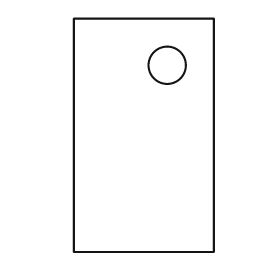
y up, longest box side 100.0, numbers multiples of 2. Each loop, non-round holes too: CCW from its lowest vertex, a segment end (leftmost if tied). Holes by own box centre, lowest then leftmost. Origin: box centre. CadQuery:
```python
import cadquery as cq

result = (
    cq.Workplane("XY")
    .moveTo(-30.0, -50.0)
    .lineTo(30.0, -50.0)
    .lineTo(30.0, 50.0)
    .lineTo(-30.0, 50.0)
    .close()
    .moveTo(10.0, 30.0)
    .circle(8.0)
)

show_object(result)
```